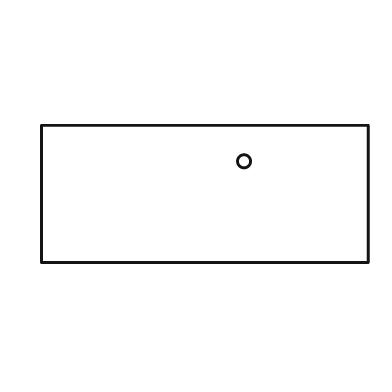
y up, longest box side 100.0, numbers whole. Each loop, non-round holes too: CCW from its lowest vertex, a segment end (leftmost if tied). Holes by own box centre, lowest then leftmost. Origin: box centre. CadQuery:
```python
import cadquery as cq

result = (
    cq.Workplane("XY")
    .moveTo(-50.0, -21.0)
    .lineTo(50.0, -21.0)
    .lineTo(50.0, 21.0)
    .lineTo(-50.0, 21.0)
    .close()
    .moveTo(12.0, 10.0)
    .circle(2.0)
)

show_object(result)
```